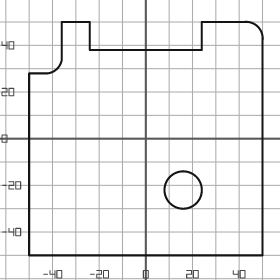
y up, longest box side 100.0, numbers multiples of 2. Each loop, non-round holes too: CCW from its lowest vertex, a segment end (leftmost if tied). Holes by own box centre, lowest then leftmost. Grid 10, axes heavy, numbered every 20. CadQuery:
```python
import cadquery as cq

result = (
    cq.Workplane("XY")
    .moveTo(-50.0, -50.0)
    .lineTo(50.0, -50.0)
    .lineTo(50.0, 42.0)
    .threePointArc((48.0, 48.0), (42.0, 50.0))
    .lineTo(24.0, 50.0)
    .lineTo(24.0, 38.0)
    .lineTo(-24.0, 38.0)
    .lineTo(-24.0, 50.0)
    .lineTo(-36.0, 50.0)
    .lineTo(-36.0, 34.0)
    .threePointArc((-38.0, 30.0), (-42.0, 28.0))
    .lineTo(-50.0, 28.0)
    .close()
    .moveTo(16.0, -22.0)
    .circle(8.0)
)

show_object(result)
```